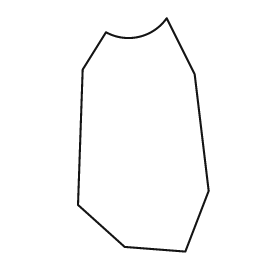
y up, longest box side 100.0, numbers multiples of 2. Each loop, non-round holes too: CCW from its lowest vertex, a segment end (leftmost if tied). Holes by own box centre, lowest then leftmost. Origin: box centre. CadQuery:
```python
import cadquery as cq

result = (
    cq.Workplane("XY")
    .moveTo(18.0, -50.0)
    .lineTo(28.0, -24.0)
    .lineTo(22.0, 26.0)
    .lineTo(10.0, 50.0)
    .threePointArc((-2.0, 42.0), (-16.0, 44.0))
    .lineTo(-26.0, 28.0)
    .lineTo(-28.0, -30.0)
    .lineTo(-8.0, -48.0)
    .close()
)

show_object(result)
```